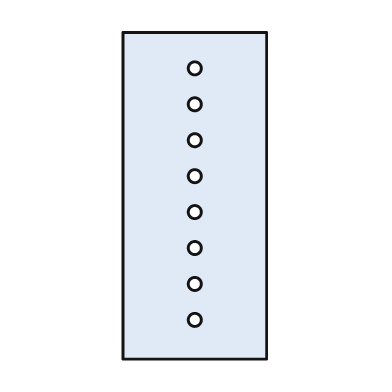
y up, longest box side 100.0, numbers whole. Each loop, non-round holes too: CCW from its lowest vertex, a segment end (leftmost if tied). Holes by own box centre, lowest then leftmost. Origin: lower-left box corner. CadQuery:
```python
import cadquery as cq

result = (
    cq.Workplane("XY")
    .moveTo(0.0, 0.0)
    .lineTo(44.0, 0.0)
    .lineTo(44.0, 100.0)
    .lineTo(0.0, 100.0)
    .close()
    .moveTo(22.0, 12.0)
    .circle(2.0)
    .moveTo(22.0, 23.0)
    .circle(2.0)
    .moveTo(22.0, 34.0)
    .circle(2.0)
    .moveTo(22.0, 45.0)
    .circle(2.0)
    .moveTo(22.0, 56.0)
    .circle(2.0)
    .moveTo(22.0, 67.0)
    .circle(2.0)
    .moveTo(22.0, 78.0)
    .circle(2.0)
    .moveTo(22.0, 89.0)
    .circle(2.0)
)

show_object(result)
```